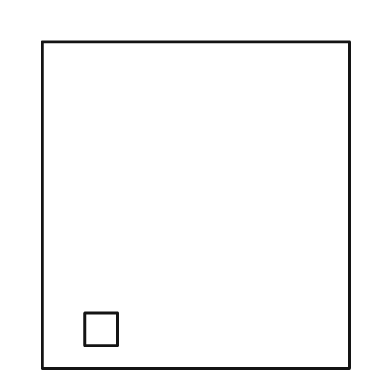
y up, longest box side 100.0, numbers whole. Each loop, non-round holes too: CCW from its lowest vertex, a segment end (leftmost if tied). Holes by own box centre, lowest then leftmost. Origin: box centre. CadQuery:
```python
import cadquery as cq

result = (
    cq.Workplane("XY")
    .moveTo(-47.0, -50.0)
    .lineTo(47.0, -50.0)
    .lineTo(47.0, 50.0)
    .lineTo(-47.0, 50.0)
    .close()
    .moveTo(-34.0, -43.0)
    .lineTo(-24.0, -43.0)
    .lineTo(-24.0, -33.0)
    .lineTo(-34.0, -33.0)
    .close()
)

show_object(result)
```